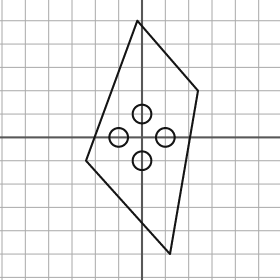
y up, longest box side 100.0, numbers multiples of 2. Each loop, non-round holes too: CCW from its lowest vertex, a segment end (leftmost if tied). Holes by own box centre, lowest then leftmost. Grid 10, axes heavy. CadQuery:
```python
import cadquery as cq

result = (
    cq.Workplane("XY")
    .moveTo(12.0, -50.0)
    .lineTo(24.0, 20.0)
    .lineTo(-2.0, 50.0)
    .lineTo(-24.0, -10.0)
    .close()
    .moveTo(0.0, -10.0)
    .circle(4.0)
    .moveTo(-10.0, 0.0)
    .circle(4.0)
    .moveTo(10.0, 0.0)
    .circle(4.0)
    .moveTo(0.0, 10.0)
    .circle(4.0)
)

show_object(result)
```